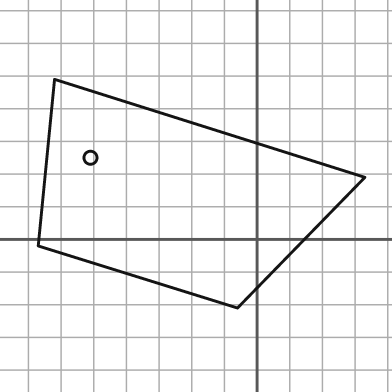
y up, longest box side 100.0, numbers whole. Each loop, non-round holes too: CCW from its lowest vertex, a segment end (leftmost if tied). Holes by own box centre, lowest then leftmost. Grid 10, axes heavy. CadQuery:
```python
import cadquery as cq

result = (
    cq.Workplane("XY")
    .moveTo(-6.0, -21.0)
    .lineTo(33.0, 19.0)
    .lineTo(-62.0, 49.0)
    .lineTo(-67.0, -2.0)
    .close()
    .moveTo(-51.0, 25.0)
    .circle(2.0)
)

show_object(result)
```